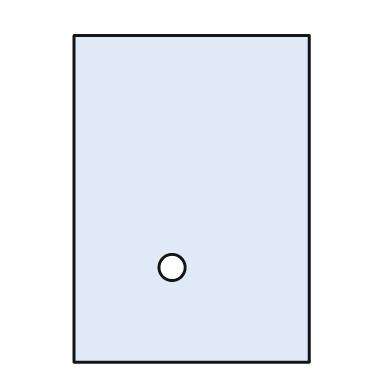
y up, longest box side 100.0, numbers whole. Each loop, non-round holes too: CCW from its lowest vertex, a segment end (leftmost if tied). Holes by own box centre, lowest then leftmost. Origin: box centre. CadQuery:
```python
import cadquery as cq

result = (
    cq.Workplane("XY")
    .moveTo(-36.0, -50.0)
    .lineTo(36.0, -50.0)
    .lineTo(36.0, 50.0)
    .lineTo(-36.0, 50.0)
    .close()
    .moveTo(-6.0, -21.0)
    .circle(4.0)
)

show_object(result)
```